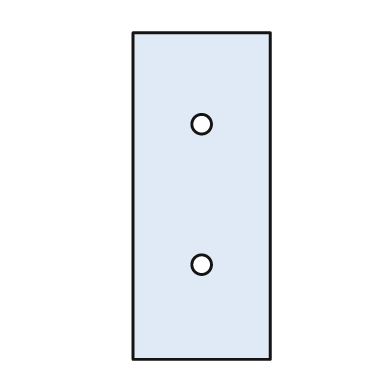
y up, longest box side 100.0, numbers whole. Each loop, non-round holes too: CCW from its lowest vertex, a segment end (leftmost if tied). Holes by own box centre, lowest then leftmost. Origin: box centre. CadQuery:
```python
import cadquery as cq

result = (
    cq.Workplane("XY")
    .moveTo(-21.0, -50.0)
    .lineTo(21.0, -50.0)
    .lineTo(21.0, 50.0)
    .lineTo(-21.0, 50.0)
    .close()
    .moveTo(0.0, -21.0)
    .circle(3.0)
    .moveTo(0.0, 22.0)
    .circle(3.0)
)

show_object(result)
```